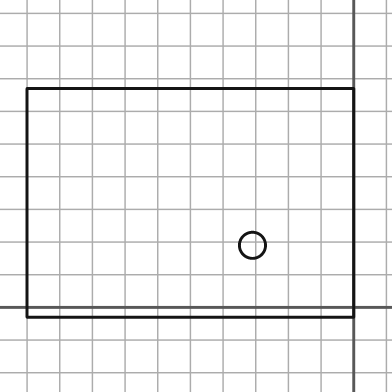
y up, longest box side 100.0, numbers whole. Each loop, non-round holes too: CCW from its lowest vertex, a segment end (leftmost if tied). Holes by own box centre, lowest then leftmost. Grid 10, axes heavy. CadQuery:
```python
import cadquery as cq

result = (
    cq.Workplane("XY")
    .moveTo(-100.0, -3.0)
    .lineTo(0.0, -3.0)
    .lineTo(0.0, 67.0)
    .lineTo(-100.0, 67.0)
    .close()
    .moveTo(-31.0, 19.0)
    .circle(4.0)
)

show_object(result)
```